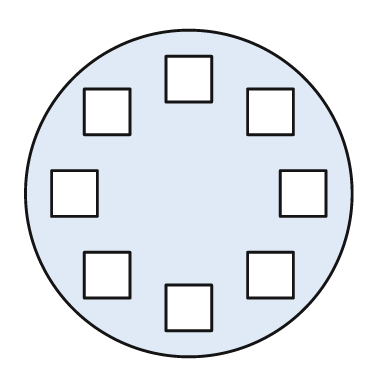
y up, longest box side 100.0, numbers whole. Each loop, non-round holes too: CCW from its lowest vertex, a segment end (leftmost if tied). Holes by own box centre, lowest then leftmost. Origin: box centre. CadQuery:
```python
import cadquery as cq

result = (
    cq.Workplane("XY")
    .moveTo(0.0, 0.0)
    .circle(50.0)
    .moveTo(-7.0, -42.0)
    .lineTo(7.0, -42.0)
    .lineTo(7.0, -28.0)
    .lineTo(-7.0, -28.0)
    .close()
    .moveTo(-32.0, -32.0)
    .lineTo(-18.0, -32.0)
    .lineTo(-18.0, -18.0)
    .lineTo(-32.0, -18.0)
    .close()
    .moveTo(18.0, -32.0)
    .lineTo(32.0, -32.0)
    .lineTo(32.0, -18.0)
    .lineTo(18.0, -18.0)
    .close()
    .moveTo(-42.0, -7.0)
    .lineTo(-28.0, -7.0)
    .lineTo(-28.0, 7.0)
    .lineTo(-42.0, 7.0)
    .close()
    .moveTo(28.0, -7.0)
    .lineTo(42.0, -7.0)
    .lineTo(42.0, 7.0)
    .lineTo(28.0, 7.0)
    .close()
    .moveTo(-32.0, 18.0)
    .lineTo(-18.0, 18.0)
    .lineTo(-18.0, 32.0)
    .lineTo(-32.0, 32.0)
    .close()
    .moveTo(18.0, 18.0)
    .lineTo(32.0, 18.0)
    .lineTo(32.0, 32.0)
    .lineTo(18.0, 32.0)
    .close()
    .moveTo(-7.0, 28.0)
    .lineTo(7.0, 28.0)
    .lineTo(7.0, 42.0)
    .lineTo(-7.0, 42.0)
    .close()
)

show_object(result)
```